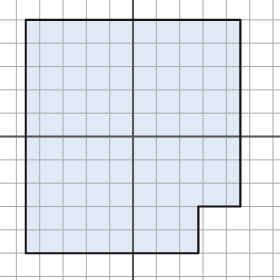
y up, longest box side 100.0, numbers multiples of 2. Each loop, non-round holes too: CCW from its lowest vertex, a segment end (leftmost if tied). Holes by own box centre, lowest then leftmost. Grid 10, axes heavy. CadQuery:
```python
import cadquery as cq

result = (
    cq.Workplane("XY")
    .moveTo(-46.0, -50.0)
    .lineTo(28.0, -50.0)
    .lineTo(28.0, -30.0)
    .lineTo(46.0, -30.0)
    .lineTo(46.0, 50.0)
    .lineTo(-46.0, 50.0)
    .close()
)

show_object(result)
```